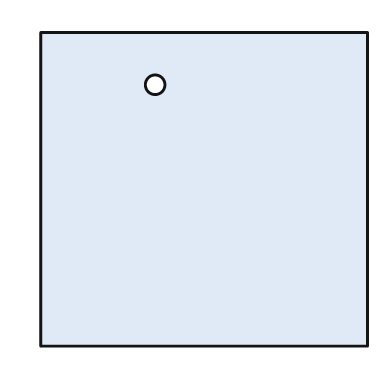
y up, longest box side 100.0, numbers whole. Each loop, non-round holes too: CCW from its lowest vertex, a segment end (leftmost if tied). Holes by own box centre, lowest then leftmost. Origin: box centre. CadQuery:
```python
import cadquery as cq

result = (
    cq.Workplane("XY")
    .moveTo(-50.0, -48.0)
    .lineTo(50.0, -48.0)
    .lineTo(50.0, 48.0)
    .lineTo(-50.0, 48.0)
    .close()
    .moveTo(-15.0, 32.0)
    .circle(3.0)
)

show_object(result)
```